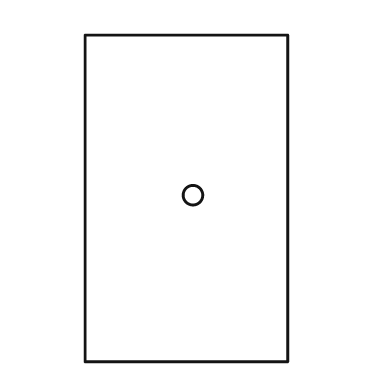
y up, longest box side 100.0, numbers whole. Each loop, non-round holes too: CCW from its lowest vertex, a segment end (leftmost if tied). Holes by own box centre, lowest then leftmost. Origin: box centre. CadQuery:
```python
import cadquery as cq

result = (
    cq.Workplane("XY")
    .moveTo(-31.0, -50.0)
    .lineTo(31.0, -50.0)
    .lineTo(31.0, 50.0)
    .lineTo(-31.0, 50.0)
    .close()
    .moveTo(2.0, 1.0)
    .circle(3.0)
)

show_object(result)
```